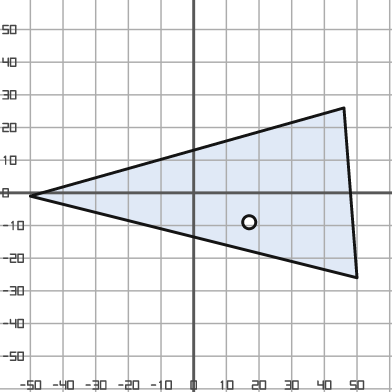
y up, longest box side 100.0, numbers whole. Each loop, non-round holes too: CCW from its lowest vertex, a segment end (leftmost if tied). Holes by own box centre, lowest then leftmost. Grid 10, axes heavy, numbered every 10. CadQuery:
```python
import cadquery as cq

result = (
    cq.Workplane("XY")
    .moveTo(50.0, -26.0)
    .lineTo(46.0, 26.0)
    .lineTo(-50.0, -1.0)
    .close()
    .moveTo(17.0, -9.0)
    .circle(2.0)
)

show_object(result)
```